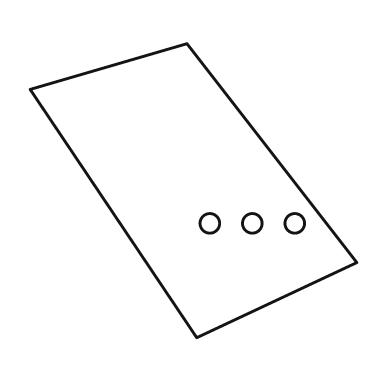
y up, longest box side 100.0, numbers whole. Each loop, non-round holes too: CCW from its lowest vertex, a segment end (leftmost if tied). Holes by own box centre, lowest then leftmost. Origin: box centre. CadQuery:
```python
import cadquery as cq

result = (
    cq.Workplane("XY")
    .moveTo(1.0, -45.0)
    .lineTo(50.0, -22.0)
    .lineTo(-2.0, 45.0)
    .lineTo(-50.0, 31.0)
    .close()
    .moveTo(5.0, -10.0)
    .circle(3.0)
    .moveTo(18.0, -10.0)
    .circle(3.0)
    .moveTo(31.0, -10.0)
    .circle(3.0)
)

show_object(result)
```